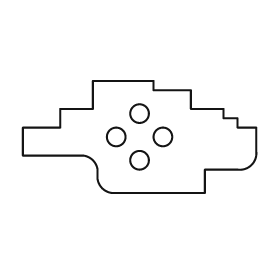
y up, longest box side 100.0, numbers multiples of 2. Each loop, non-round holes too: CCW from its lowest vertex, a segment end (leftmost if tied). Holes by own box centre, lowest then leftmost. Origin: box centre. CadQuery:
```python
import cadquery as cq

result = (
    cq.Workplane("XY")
    .moveTo(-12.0, -24.0)
    .lineTo(28.0, -24.0)
    .lineTo(28.0, -14.0)
    .lineTo(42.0, -14.0)
    .threePointArc((48.0, -12.0), (50.0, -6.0))
    .lineTo(50.0, 4.0)
    .lineTo(42.0, 4.0)
    .lineTo(42.0, 8.0)
    .lineTo(36.0, 8.0)
    .lineTo(36.0, 12.0)
    .lineTo(22.0, 12.0)
    .lineTo(22.0, 20.0)
    .lineTo(6.0, 20.0)
    .lineTo(6.0, 24.0)
    .lineTo(-20.0, 24.0)
    .lineTo(-20.0, 12.0)
    .lineTo(-34.0, 12.0)
    .lineTo(-34.0, 4.0)
    .lineTo(-50.0, 4.0)
    .lineTo(-50.0, -8.0)
    .lineTo(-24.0, -8.0)
    .threePointArc((-20.0, -10.0), (-18.0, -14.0))
    .lineTo(-18.0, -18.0)
    .threePointArc((-16.0, -22.0), (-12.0, -24.0))
    .close()
    .moveTo(0.0, -10.0)
    .circle(4.0)
    .moveTo(-10.0, 0.0)
    .circle(4.0)
    .moveTo(10.0, 0.0)
    .circle(4.0)
    .moveTo(0.0, 10.0)
    .circle(4.0)
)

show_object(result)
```